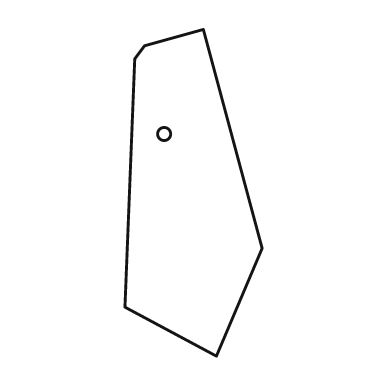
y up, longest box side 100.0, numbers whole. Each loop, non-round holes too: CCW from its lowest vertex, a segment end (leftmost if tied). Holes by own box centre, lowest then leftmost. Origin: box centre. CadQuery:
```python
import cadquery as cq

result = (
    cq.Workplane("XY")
    .moveTo(7.0, -50.0)
    .lineTo(21.0, -17.0)
    .lineTo(3.0, 50.0)
    .lineTo(-15.0, 45.0)
    .lineTo(-18.0, 41.0)
    .lineTo(-21.0, -35.0)
    .close()
    .moveTo(-9.0, 18.0)
    .circle(2.0)
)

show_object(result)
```